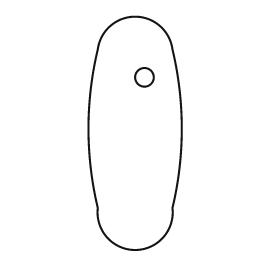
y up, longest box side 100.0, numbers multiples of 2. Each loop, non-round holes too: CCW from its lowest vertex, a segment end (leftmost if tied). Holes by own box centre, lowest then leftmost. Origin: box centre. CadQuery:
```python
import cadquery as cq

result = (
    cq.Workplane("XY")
    .moveTo(-16.0, -32.0)
    .threePointArc((0.0, -50.0), (16.0, -32.0))
    .threePointArc((20.0, 2.0), (16.0, 36.0))
    .threePointArc((0.0, 50.0), (-16.0, 36.0))
    .threePointArc((-20.0, 2.0), (-16.0, -32.0))
    .close()
    .moveTo(4.0, 24.0)
    .circle(4.0)
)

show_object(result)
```